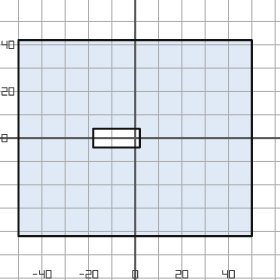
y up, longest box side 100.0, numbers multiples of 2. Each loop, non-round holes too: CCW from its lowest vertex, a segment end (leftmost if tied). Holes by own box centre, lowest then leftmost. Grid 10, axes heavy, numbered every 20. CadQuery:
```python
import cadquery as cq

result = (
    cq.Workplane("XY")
    .moveTo(-50.0, -42.0)
    .lineTo(50.0, -42.0)
    .lineTo(50.0, 42.0)
    .lineTo(-50.0, 42.0)
    .close()
    .moveTo(-18.0, -4.0)
    .lineTo(2.0, -4.0)
    .lineTo(2.0, 4.0)
    .lineTo(-18.0, 4.0)
    .close()
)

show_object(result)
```